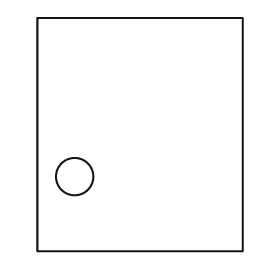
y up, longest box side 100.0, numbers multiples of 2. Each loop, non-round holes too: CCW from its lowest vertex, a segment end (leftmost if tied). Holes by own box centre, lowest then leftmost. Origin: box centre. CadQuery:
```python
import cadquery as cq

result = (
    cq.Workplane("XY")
    .moveTo(-44.0, -50.0)
    .lineTo(44.0, -50.0)
    .lineTo(44.0, 50.0)
    .lineTo(-44.0, 50.0)
    .close()
    .moveTo(-28.0, -18.0)
    .circle(8.0)
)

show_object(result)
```